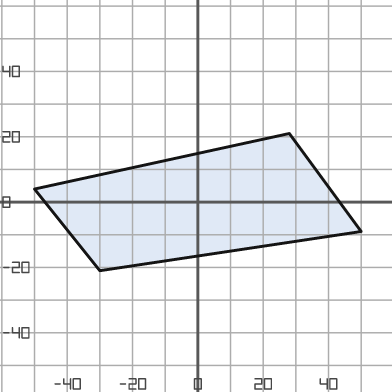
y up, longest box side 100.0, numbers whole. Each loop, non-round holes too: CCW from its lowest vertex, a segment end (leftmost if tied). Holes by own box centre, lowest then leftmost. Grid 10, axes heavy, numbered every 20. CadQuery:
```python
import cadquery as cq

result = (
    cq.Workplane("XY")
    .moveTo(-30.0, -21.0)
    .lineTo(50.0, -9.0)
    .lineTo(28.0, 21.0)
    .lineTo(-50.0, 4.0)
    .close()
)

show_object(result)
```